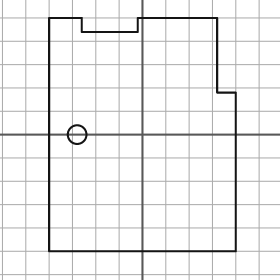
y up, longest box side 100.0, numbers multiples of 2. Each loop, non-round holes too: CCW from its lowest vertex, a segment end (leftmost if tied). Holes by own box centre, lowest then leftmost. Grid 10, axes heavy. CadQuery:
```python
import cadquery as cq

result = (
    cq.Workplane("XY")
    .moveTo(-40.0, -50.0)
    .lineTo(40.0, -50.0)
    .lineTo(40.0, 18.0)
    .lineTo(32.0, 18.0)
    .lineTo(32.0, 50.0)
    .lineTo(-2.0, 50.0)
    .lineTo(-2.0, 44.0)
    .lineTo(-26.0, 44.0)
    .lineTo(-26.0, 50.0)
    .lineTo(-40.0, 50.0)
    .close()
    .moveTo(-28.0, 0.0)
    .circle(4.0)
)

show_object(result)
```